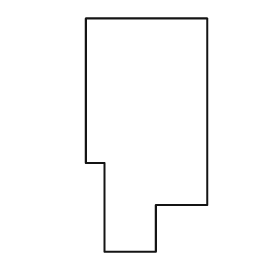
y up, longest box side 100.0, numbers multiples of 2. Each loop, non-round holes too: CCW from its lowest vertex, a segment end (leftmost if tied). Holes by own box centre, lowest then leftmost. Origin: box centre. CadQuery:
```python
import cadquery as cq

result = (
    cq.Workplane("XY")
    .moveTo(-18.0, -50.0)
    .lineTo(4.0, -50.0)
    .lineTo(4.0, -30.0)
    .lineTo(26.0, -30.0)
    .lineTo(26.0, 50.0)
    .lineTo(-26.0, 50.0)
    .lineTo(-26.0, -12.0)
    .lineTo(-18.0, -12.0)
    .close()
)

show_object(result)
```